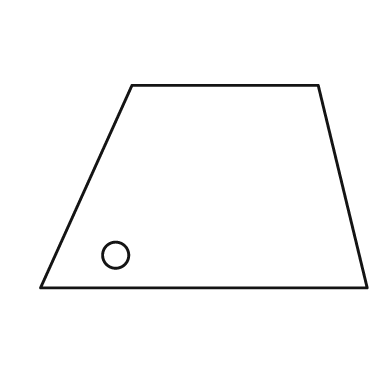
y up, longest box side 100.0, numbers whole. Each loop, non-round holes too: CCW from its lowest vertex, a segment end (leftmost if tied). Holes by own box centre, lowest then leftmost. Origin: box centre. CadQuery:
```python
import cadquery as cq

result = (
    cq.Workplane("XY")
    .moveTo(-50.0, -31.0)
    .lineTo(50.0, -31.0)
    .lineTo(35.0, 31.0)
    .lineTo(-22.0, 31.0)
    .close()
    .moveTo(-27.0, -21.0)
    .circle(4.0)
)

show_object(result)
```